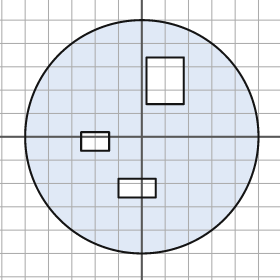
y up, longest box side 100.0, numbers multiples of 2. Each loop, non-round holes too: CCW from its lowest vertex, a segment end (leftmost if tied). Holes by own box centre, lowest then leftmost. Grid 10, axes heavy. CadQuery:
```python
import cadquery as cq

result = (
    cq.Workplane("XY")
    .moveTo(0.0, 0.0)
    .circle(50.0)
    .moveTo(-10.0, -26.0)
    .lineTo(6.0, -26.0)
    .lineTo(6.0, -18.0)
    .lineTo(-10.0, -18.0)
    .close()
    .moveTo(-26.0, -6.0)
    .lineTo(-14.0, -6.0)
    .lineTo(-14.0, 2.0)
    .lineTo(-26.0, 2.0)
    .close()
    .moveTo(2.0, 14.0)
    .lineTo(18.0, 14.0)
    .lineTo(18.0, 34.0)
    .lineTo(2.0, 34.0)
    .close()
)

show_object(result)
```